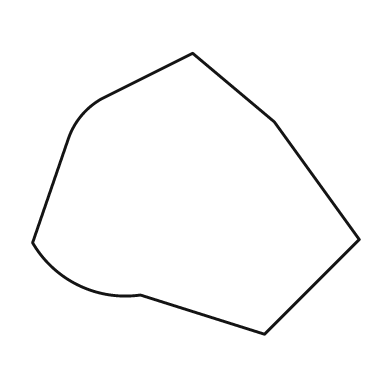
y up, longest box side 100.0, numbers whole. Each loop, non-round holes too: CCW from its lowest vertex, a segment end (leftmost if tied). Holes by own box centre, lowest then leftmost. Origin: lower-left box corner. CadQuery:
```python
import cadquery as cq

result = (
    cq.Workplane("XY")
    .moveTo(71.0, 0.0)
    .lineTo(100.0, 29.0)
    .lineTo(74.0, 65.0)
    .lineTo(49.0, 86.0)
    .lineTo(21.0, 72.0)
    .threePointArc((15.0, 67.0), (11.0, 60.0))
    .lineTo(0.0, 28.0)
    .threePointArc((14.0, 15.0), (33.0, 12.0))
    .close()
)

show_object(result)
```